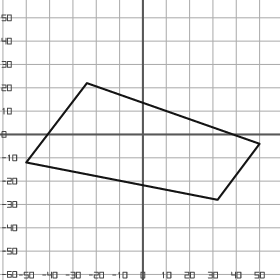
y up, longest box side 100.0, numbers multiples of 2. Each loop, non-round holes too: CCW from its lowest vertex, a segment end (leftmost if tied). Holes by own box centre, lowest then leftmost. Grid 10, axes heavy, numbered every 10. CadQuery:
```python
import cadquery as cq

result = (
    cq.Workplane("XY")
    .moveTo(32.0, -28.0)
    .lineTo(50.0, -4.0)
    .lineTo(-24.0, 22.0)
    .lineTo(-50.0, -12.0)
    .close()
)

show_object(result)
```